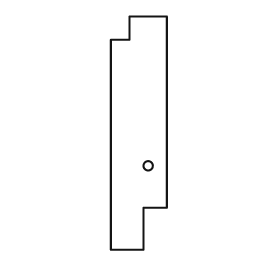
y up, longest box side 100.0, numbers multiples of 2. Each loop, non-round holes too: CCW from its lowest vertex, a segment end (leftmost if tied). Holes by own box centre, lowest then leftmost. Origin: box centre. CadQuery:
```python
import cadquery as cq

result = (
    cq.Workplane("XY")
    .moveTo(-12.0, -50.0)
    .lineTo(2.0, -50.0)
    .lineTo(2.0, -32.0)
    .lineTo(12.0, -32.0)
    .lineTo(12.0, 50.0)
    .lineTo(-4.0, 50.0)
    .lineTo(-4.0, 40.0)
    .lineTo(-12.0, 40.0)
    .close()
    .moveTo(4.0, -14.0)
    .circle(2.0)
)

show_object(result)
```